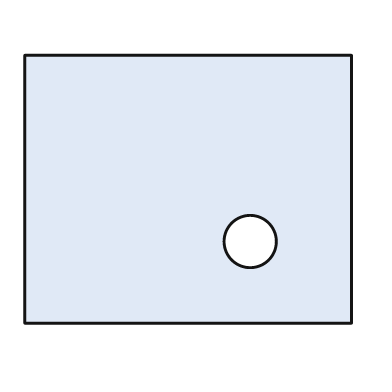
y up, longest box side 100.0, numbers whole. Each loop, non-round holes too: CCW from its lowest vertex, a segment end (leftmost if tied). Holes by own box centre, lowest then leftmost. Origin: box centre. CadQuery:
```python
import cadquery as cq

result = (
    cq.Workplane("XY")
    .moveTo(-50.0, -41.0)
    .lineTo(50.0, -41.0)
    .lineTo(50.0, 41.0)
    .lineTo(-50.0, 41.0)
    .close()
    .moveTo(19.0, -16.0)
    .circle(8.0)
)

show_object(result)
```